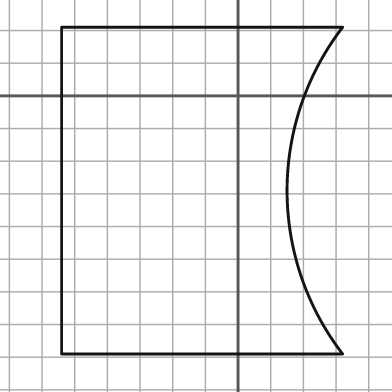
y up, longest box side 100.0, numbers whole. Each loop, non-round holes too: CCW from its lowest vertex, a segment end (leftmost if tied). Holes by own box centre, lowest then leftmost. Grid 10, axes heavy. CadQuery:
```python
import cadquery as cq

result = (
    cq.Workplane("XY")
    .moveTo(-54.0, -79.0)
    .lineTo(32.0, -79.0)
    .threePointArc((15.0, -29.0), (32.0, 21.0))
    .lineTo(-54.0, 21.0)
    .close()
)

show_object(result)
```